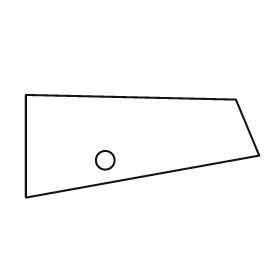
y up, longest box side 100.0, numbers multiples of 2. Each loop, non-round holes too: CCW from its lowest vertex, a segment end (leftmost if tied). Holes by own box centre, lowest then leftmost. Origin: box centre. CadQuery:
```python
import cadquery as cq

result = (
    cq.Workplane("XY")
    .moveTo(-50.0, -22.0)
    .lineTo(50.0, -4.0)
    .lineTo(40.0, 20.0)
    .lineTo(-50.0, 22.0)
    .close()
    .moveTo(-16.0, -6.0)
    .circle(4.0)
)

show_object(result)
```